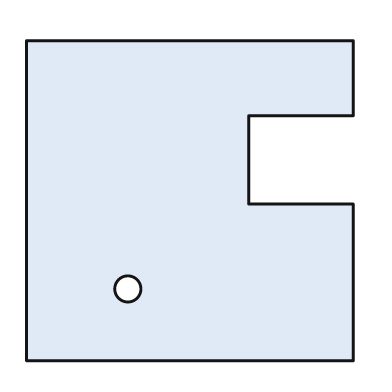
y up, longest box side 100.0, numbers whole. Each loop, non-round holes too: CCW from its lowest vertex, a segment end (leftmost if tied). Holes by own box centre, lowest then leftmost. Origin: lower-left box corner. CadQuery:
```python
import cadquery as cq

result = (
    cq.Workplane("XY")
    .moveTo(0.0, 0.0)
    .lineTo(100.0, 0.0)
    .lineTo(100.0, 48.0)
    .lineTo(68.0, 48.0)
    .lineTo(68.0, 75.0)
    .lineTo(100.0, 75.0)
    .lineTo(100.0, 98.0)
    .lineTo(0.0, 98.0)
    .close()
    .moveTo(31.0, 22.0)
    .circle(4.0)
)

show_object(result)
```